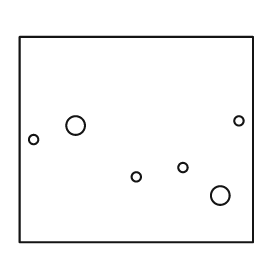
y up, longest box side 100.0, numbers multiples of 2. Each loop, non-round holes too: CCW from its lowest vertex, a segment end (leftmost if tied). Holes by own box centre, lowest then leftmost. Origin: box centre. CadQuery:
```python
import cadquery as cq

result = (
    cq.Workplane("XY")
    .moveTo(-50.0, -44.0)
    .lineTo(50.0, -44.0)
    .lineTo(50.0, 44.0)
    .lineTo(-50.0, 44.0)
    .close()
    .moveTo(36.0, -24.0)
    .circle(4.0)
    .moveTo(0.0, -16.0)
    .circle(2.0)
    .moveTo(20.0, -12.0)
    .circle(2.0)
    .moveTo(-44.0, 0.0)
    .circle(2.0)
    .moveTo(-26.0, 6.0)
    .circle(4.0)
    .moveTo(44.0, 8.0)
    .circle(2.0)
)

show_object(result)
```